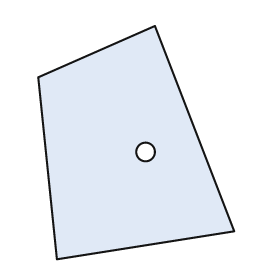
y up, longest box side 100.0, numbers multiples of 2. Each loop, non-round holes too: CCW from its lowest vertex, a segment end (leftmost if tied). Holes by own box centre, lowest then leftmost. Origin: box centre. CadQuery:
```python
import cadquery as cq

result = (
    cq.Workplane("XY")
    .moveTo(-34.0, -50.0)
    .lineTo(42.0, -38.0)
    .lineTo(8.0, 50.0)
    .lineTo(-42.0, 28.0)
    .close()
    .moveTo(4.0, -4.0)
    .circle(4.0)
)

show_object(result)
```